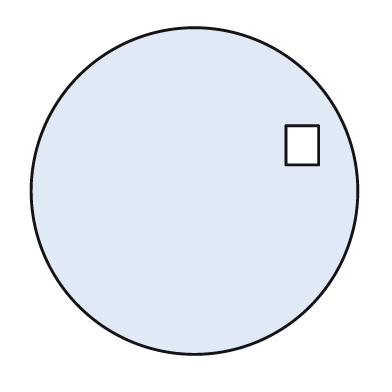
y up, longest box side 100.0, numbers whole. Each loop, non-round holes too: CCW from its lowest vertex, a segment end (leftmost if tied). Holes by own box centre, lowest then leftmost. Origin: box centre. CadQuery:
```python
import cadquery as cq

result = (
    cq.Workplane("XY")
    .moveTo(0.0, 0.0)
    .circle(50.0)
    .moveTo(28.0, 8.0)
    .lineTo(38.0, 8.0)
    .lineTo(38.0, 20.0)
    .lineTo(28.0, 20.0)
    .close()
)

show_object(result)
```